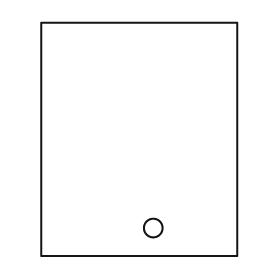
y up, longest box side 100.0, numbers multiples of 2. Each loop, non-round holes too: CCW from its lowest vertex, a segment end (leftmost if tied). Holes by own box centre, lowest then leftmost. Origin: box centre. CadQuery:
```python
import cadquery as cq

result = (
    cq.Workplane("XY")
    .moveTo(-42.0, -50.0)
    .lineTo(42.0, -50.0)
    .lineTo(42.0, 50.0)
    .lineTo(-42.0, 50.0)
    .close()
    .moveTo(6.0, -38.0)
    .circle(4.0)
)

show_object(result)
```